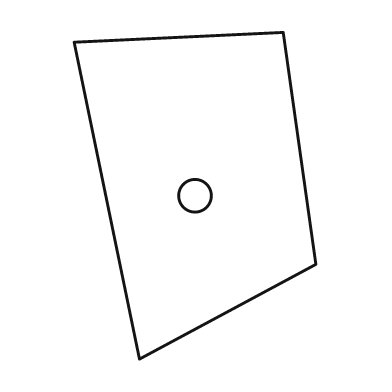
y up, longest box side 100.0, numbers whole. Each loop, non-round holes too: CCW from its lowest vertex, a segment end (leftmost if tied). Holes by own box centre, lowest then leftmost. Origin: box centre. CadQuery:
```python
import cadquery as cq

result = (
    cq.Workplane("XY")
    .moveTo(-17.0, -50.0)
    .lineTo(37.0, -21.0)
    .lineTo(27.0, 50.0)
    .lineTo(-37.0, 47.0)
    .close()
    .moveTo(0.0, 0.0)
    .circle(5.0)
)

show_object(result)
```